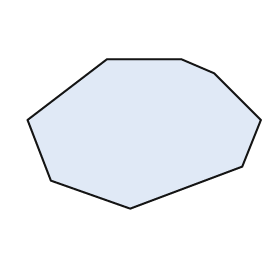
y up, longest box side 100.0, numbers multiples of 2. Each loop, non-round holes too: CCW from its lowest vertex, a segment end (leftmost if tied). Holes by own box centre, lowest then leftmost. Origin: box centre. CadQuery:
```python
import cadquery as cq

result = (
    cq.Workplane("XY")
    .moveTo(-6.0, -32.0)
    .lineTo(42.0, -14.0)
    .lineTo(50.0, 6.0)
    .lineTo(30.0, 26.0)
    .lineTo(16.0, 32.0)
    .lineTo(-16.0, 32.0)
    .lineTo(-50.0, 6.0)
    .lineTo(-40.0, -20.0)
    .close()
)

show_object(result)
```